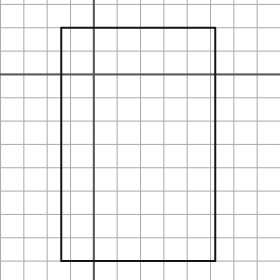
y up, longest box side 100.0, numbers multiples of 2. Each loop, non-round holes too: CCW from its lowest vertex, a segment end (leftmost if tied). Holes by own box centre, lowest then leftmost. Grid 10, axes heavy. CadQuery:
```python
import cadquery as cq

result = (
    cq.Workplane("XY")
    .moveTo(-14.0, -80.0)
    .lineTo(52.0, -80.0)
    .lineTo(52.0, 20.0)
    .lineTo(-14.0, 20.0)
    .close()
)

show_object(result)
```